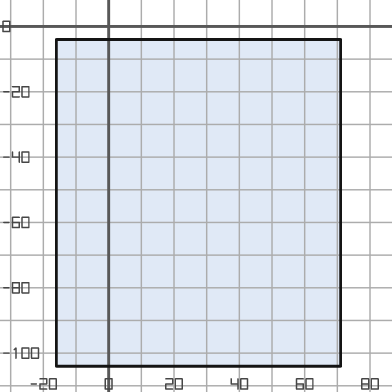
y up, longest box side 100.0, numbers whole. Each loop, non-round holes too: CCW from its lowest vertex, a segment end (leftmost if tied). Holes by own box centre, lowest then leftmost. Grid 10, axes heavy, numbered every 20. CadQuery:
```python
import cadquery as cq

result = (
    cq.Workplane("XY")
    .moveTo(-16.0, -104.0)
    .lineTo(71.0, -104.0)
    .lineTo(71.0, -4.0)
    .lineTo(-16.0, -4.0)
    .close()
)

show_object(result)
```